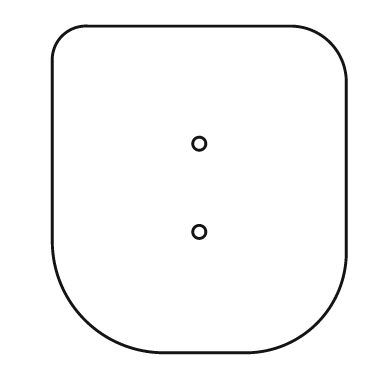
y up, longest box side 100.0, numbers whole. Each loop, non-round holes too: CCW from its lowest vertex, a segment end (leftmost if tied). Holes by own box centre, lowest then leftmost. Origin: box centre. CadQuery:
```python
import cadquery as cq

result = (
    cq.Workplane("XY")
    .moveTo(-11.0, -50.0)
    .lineTo(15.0, -50.0)
    .threePointArc((36.0, -41.0), (45.0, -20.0))
    .lineTo(45.0, 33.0)
    .threePointArc((40.0, 45.0), (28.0, 50.0))
    .lineTo(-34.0, 50.0)
    .threePointArc((-42.0, 47.0), (-45.0, 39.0))
    .lineTo(-45.0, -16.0)
    .threePointArc((-35.0, -40.0), (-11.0, -50.0))
    .close()
    .moveTo(0.0, -13.0)
    .circle(2.0)
    .moveTo(0.0, 14.0)
    .circle(2.0)
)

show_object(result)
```